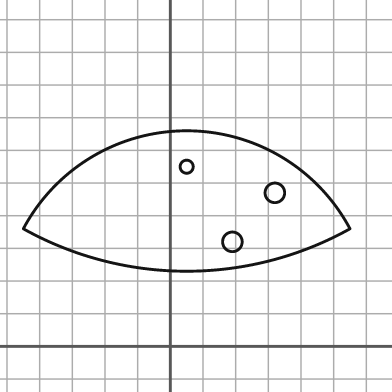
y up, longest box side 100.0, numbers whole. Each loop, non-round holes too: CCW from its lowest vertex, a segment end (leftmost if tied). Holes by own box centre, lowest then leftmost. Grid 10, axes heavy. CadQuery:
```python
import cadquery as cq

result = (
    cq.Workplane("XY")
    .moveTo(-45.0, 36.0)
    .threePointArc((5.0, 23.0), (55.0, 36.0))
    .threePointArc((5.0, 66.0), (-45.0, 36.0))
    .close()
    .moveTo(19.0, 32.0)
    .circle(3.0)
    .moveTo(32.0, 47.0)
    .circle(3.0)
    .moveTo(5.0, 55.0)
    .circle(2.0)
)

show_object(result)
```